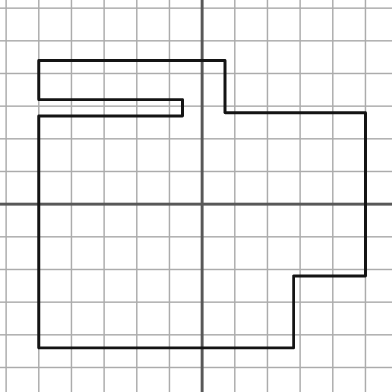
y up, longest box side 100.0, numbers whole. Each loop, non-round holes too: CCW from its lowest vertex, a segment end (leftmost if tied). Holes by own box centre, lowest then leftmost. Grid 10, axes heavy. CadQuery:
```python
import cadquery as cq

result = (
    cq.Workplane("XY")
    .moveTo(-50.0, -44.0)
    .lineTo(28.0, -44.0)
    .lineTo(28.0, -22.0)
    .lineTo(50.0, -22.0)
    .lineTo(50.0, 28.0)
    .lineTo(7.0, 28.0)
    .lineTo(7.0, 44.0)
    .lineTo(-50.0, 44.0)
    .lineTo(-50.0, 32.0)
    .lineTo(-6.0, 32.0)
    .lineTo(-6.0, 27.0)
    .lineTo(-50.0, 27.0)
    .close()
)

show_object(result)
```